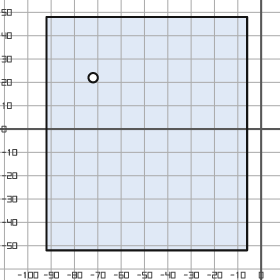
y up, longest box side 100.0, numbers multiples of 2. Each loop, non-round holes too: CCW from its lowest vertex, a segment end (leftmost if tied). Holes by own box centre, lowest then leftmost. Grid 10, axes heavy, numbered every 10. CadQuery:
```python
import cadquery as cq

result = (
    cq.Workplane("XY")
    .moveTo(-92.0, -52.0)
    .lineTo(-6.0, -52.0)
    .lineTo(-6.0, 48.0)
    .lineTo(-92.0, 48.0)
    .close()
    .moveTo(-72.0, 22.0)
    .circle(2.0)
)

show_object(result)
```